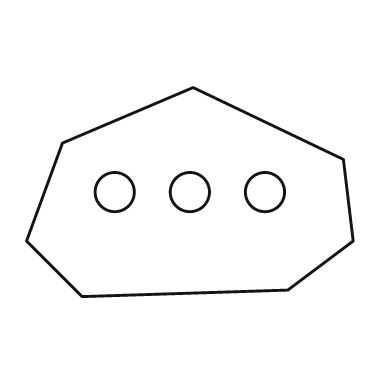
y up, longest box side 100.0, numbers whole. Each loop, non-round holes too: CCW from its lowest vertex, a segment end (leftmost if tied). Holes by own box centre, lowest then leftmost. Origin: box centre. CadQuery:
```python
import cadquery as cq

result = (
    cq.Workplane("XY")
    .moveTo(-33.0, -32.0)
    .lineTo(30.0, -30.0)
    .lineTo(50.0, -15.0)
    .lineTo(47.0, 10.0)
    .lineTo(1.0, 32.0)
    .lineTo(-39.0, 15.0)
    .lineTo(-50.0, -15.0)
    .close()
    .moveTo(-23.0, 0.0)
    .circle(6.0)
    .moveTo(0.0, 0.0)
    .circle(6.0)
    .moveTo(23.0, 0.0)
    .circle(6.0)
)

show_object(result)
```